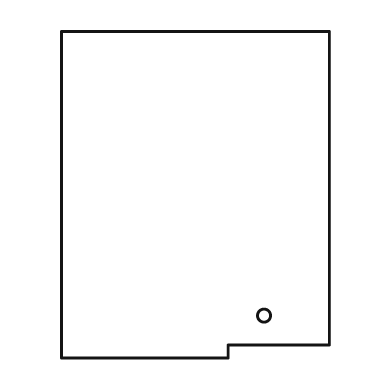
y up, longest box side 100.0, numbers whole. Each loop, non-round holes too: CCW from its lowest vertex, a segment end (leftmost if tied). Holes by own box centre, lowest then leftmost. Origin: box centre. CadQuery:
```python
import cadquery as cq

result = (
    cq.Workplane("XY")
    .moveTo(-41.0, -50.0)
    .lineTo(10.0, -50.0)
    .lineTo(10.0, -46.0)
    .lineTo(41.0, -46.0)
    .lineTo(41.0, 50.0)
    .lineTo(-41.0, 50.0)
    .close()
    .moveTo(21.0, -37.0)
    .circle(2.0)
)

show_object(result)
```